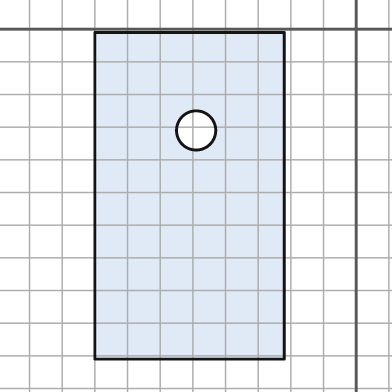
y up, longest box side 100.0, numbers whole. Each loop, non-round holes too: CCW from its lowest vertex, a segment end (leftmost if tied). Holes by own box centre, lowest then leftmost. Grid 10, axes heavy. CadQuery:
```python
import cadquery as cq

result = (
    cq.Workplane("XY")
    .moveTo(-80.0, -101.0)
    .lineTo(-22.0, -101.0)
    .lineTo(-22.0, -1.0)
    .lineTo(-80.0, -1.0)
    .close()
    .moveTo(-49.0, -31.0)
    .circle(6.0)
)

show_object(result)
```